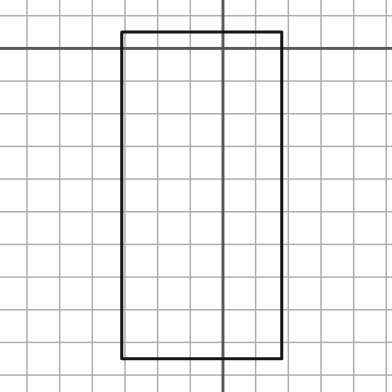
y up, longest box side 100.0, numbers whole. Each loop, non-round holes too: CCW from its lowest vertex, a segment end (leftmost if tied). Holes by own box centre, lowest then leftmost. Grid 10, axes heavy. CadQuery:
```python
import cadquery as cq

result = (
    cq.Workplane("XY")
    .moveTo(-31.0, -95.0)
    .lineTo(18.0, -95.0)
    .lineTo(18.0, 5.0)
    .lineTo(-31.0, 5.0)
    .close()
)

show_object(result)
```